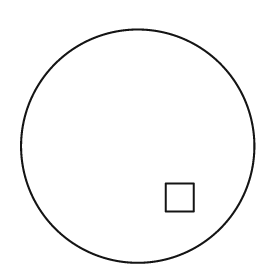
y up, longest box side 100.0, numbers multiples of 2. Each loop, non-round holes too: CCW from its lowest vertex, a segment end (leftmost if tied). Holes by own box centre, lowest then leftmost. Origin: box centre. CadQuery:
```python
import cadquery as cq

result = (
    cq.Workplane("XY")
    .moveTo(0.0, 0.0)
    .circle(50.0)
    .moveTo(12.0, -28.0)
    .lineTo(24.0, -28.0)
    .lineTo(24.0, -16.0)
    .lineTo(12.0, -16.0)
    .close()
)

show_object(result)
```